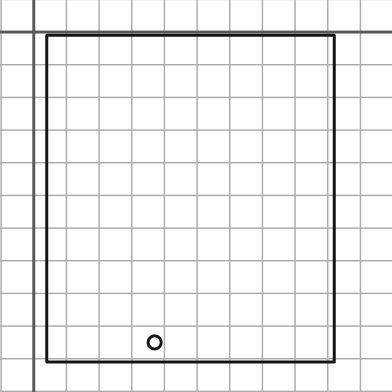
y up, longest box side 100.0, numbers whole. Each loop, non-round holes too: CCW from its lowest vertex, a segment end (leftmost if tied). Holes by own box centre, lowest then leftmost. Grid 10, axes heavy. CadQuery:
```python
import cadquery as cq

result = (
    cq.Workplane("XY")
    .moveTo(4.0, -101.0)
    .lineTo(92.0, -101.0)
    .lineTo(92.0, -1.0)
    .lineTo(4.0, -1.0)
    .close()
    .moveTo(37.0, -95.0)
    .circle(2.0)
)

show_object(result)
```